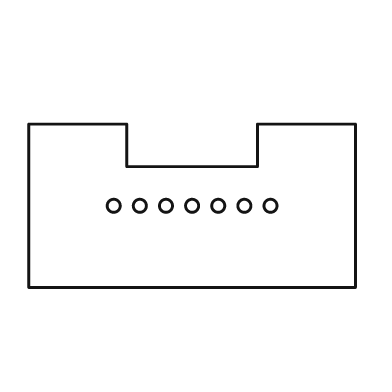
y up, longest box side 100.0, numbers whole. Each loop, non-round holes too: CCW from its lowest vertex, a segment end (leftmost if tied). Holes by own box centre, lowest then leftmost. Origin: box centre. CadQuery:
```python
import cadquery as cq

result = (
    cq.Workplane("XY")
    .moveTo(-50.0, -25.0)
    .lineTo(50.0, -25.0)
    .lineTo(50.0, 25.0)
    .lineTo(20.0, 25.0)
    .lineTo(20.0, 12.0)
    .lineTo(-20.0, 12.0)
    .lineTo(-20.0, 25.0)
    .lineTo(-50.0, 25.0)
    .close()
    .moveTo(-24.0, 0.0)
    .circle(2.0)
    .moveTo(-16.0, 0.0)
    .circle(2.0)
    .moveTo(-8.0, 0.0)
    .circle(2.0)
    .moveTo(0.0, 0.0)
    .circle(2.0)
    .moveTo(8.0, 0.0)
    .circle(2.0)
    .moveTo(16.0, 0.0)
    .circle(2.0)
    .moveTo(24.0, 0.0)
    .circle(2.0)
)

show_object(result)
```